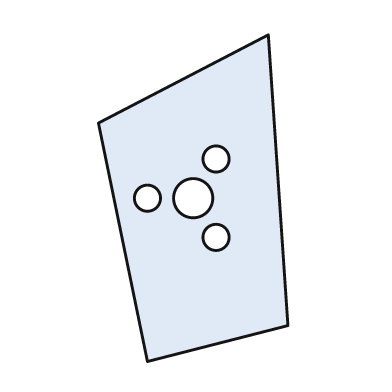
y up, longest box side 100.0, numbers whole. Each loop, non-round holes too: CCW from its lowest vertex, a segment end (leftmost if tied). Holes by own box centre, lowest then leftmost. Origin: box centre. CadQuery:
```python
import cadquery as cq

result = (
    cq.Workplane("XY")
    .moveTo(-14.0, -50.0)
    .lineTo(29.0, -39.0)
    .lineTo(23.0, 50.0)
    .lineTo(-29.0, 23.0)
    .close()
    .moveTo(7.0, -12.0)
    .circle(4.0)
    .moveTo(-14.0, 0.0)
    .circle(4.0)
    .moveTo(0.0, 0.0)
    .circle(6.0)
    .moveTo(7.0, 12.0)
    .circle(4.0)
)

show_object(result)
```